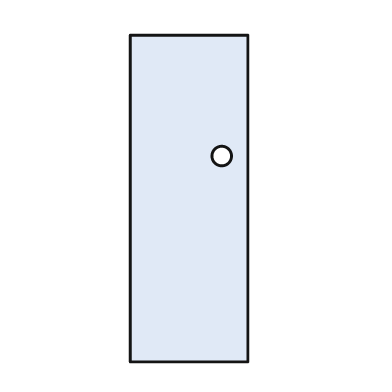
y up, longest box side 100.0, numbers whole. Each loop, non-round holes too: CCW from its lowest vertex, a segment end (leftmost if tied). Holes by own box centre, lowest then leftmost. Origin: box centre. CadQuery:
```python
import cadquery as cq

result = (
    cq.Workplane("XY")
    .moveTo(-18.0, -50.0)
    .lineTo(18.0, -50.0)
    .lineTo(18.0, 50.0)
    .lineTo(-18.0, 50.0)
    .close()
    .moveTo(10.0, 13.0)
    .circle(3.0)
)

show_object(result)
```